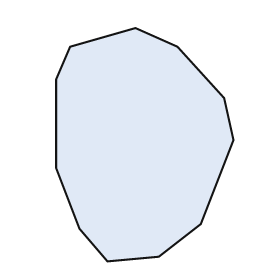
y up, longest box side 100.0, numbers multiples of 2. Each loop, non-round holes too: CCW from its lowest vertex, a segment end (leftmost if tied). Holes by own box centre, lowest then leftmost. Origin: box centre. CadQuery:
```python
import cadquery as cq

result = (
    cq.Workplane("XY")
    .moveTo(-16.0, -50.0)
    .lineTo(6.0, -48.0)
    .lineTo(24.0, -34.0)
    .lineTo(38.0, 2.0)
    .lineTo(34.0, 20.0)
    .lineTo(14.0, 42.0)
    .lineTo(-4.0, 50.0)
    .lineTo(-32.0, 42.0)
    .lineTo(-38.0, 28.0)
    .lineTo(-38.0, -10.0)
    .lineTo(-28.0, -36.0)
    .close()
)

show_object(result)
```